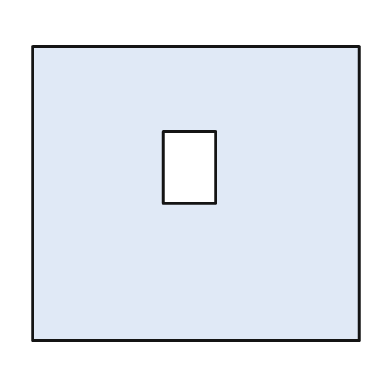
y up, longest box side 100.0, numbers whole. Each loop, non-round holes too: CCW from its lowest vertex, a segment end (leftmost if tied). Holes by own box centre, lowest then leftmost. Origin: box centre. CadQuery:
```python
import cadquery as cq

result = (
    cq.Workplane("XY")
    .moveTo(-50.0, -45.0)
    .lineTo(50.0, -45.0)
    .lineTo(50.0, 45.0)
    .lineTo(-50.0, 45.0)
    .close()
    .moveTo(-10.0, -3.0)
    .lineTo(6.0, -3.0)
    .lineTo(6.0, 19.0)
    .lineTo(-10.0, 19.0)
    .close()
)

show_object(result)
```